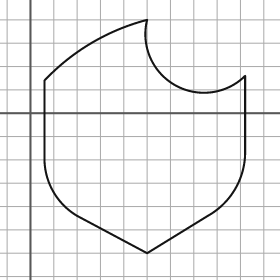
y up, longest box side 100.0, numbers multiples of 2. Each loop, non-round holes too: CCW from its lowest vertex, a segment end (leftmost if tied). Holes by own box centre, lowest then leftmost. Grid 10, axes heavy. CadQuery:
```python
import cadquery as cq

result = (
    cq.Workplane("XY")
    .moveTo(50.0, -60.0)
    .lineTo(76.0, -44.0)
    .threePointArc((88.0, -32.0), (92.0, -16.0))
    .lineTo(92.0, 16.0)
    .threePointArc((62.0, 12.0), (50.0, 40.0))
    .threePointArc((26.0, 30.0), (6.0, 14.0))
    .lineTo(6.0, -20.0)
    .threePointArc((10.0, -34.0), (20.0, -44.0))
    .close()
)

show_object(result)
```